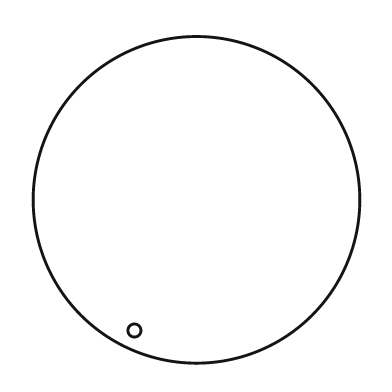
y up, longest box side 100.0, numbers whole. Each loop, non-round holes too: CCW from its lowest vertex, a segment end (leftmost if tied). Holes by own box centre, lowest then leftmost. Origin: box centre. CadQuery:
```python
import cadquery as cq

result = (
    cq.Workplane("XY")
    .moveTo(0.0, 0.0)
    .circle(50.0)
    .moveTo(-19.0, -40.0)
    .circle(2.0)
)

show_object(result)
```